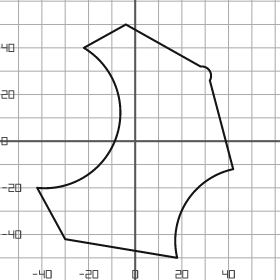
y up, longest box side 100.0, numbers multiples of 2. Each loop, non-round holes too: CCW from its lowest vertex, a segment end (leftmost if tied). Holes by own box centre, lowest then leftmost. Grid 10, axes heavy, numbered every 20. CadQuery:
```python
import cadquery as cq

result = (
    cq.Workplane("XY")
    .moveTo(18.0, -50.0)
    .threePointArc((22.0, -26.0), (42.0, -12.0))
    .lineTo(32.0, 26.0)
    .threePointArc((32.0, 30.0), (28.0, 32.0))
    .lineTo(-4.0, 50.0)
    .lineTo(-22.0, 40.0)
    .threePointArc((-8.0, 2.0), (-42.0, -20.0))
    .lineTo(-30.0, -42.0)
    .close()
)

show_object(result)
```